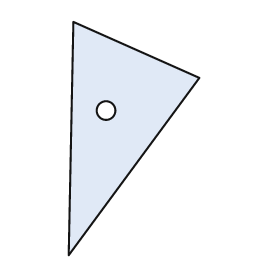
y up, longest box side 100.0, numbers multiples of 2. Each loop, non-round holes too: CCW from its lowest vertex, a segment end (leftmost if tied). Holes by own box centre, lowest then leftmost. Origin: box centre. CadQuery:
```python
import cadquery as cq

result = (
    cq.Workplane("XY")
    .moveTo(-28.0, -50.0)
    .lineTo(28.0, 26.0)
    .lineTo(-26.0, 50.0)
    .close()
    .moveTo(-12.0, 12.0)
    .circle(4.0)
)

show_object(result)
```